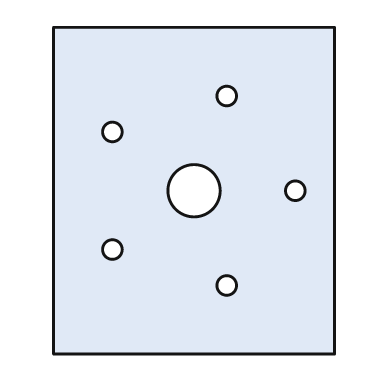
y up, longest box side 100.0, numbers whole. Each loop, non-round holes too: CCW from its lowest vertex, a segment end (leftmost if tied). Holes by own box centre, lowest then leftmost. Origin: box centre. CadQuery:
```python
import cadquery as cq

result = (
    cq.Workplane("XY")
    .moveTo(-43.0, -50.0)
    .lineTo(43.0, -50.0)
    .lineTo(43.0, 50.0)
    .lineTo(-43.0, 50.0)
    .close()
    .moveTo(10.0, -29.0)
    .circle(3.0)
    .moveTo(-25.0, -18.0)
    .circle(3.0)
    .moveTo(0.0, 0.0)
    .circle(8.0)
    .moveTo(31.0, 0.0)
    .circle(3.0)
    .moveTo(-25.0, 18.0)
    .circle(3.0)
    .moveTo(10.0, 29.0)
    .circle(3.0)
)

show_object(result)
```